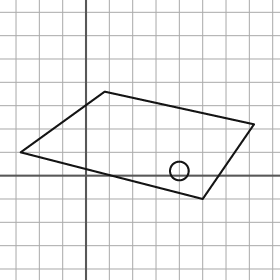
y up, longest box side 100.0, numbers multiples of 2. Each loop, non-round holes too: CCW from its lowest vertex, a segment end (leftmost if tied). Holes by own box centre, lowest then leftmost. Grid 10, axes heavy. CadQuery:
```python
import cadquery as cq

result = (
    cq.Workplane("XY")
    .moveTo(50.0, -10.0)
    .lineTo(72.0, 22.0)
    .lineTo(8.0, 36.0)
    .lineTo(-28.0, 10.0)
    .close()
    .moveTo(40.0, 2.0)
    .circle(4.0)
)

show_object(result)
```